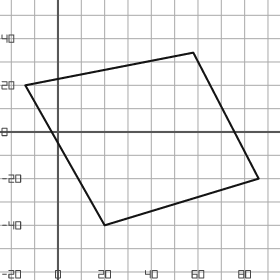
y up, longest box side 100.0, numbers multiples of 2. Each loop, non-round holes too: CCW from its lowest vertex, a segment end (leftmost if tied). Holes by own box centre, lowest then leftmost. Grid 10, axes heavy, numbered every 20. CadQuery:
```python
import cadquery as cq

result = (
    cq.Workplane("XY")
    .moveTo(20.0, -40.0)
    .lineTo(86.0, -20.0)
    .lineTo(58.0, 34.0)
    .lineTo(-14.0, 20.0)
    .close()
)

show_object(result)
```